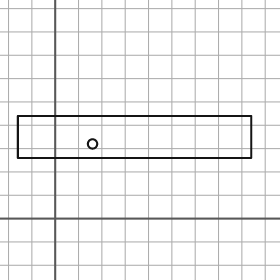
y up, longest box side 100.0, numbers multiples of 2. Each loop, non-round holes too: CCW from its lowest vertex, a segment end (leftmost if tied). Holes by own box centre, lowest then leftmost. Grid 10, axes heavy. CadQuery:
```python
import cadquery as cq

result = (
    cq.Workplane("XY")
    .moveTo(-16.0, 26.0)
    .lineTo(84.0, 26.0)
    .lineTo(84.0, 44.0)
    .lineTo(-16.0, 44.0)
    .close()
    .moveTo(16.0, 32.0)
    .circle(2.0)
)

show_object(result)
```